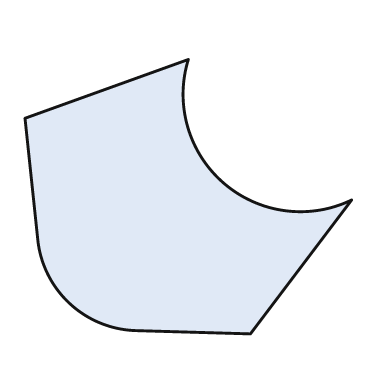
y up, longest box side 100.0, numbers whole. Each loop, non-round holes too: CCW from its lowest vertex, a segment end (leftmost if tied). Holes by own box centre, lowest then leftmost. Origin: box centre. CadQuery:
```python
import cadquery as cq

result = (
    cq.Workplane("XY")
    .moveTo(19.0, -42.0)
    .lineTo(50.0, -1.0)
    .threePointArc((11.0, 4.0), (0.0, 42.0))
    .lineTo(-50.0, 24.0)
    .lineTo(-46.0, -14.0)
    .threePointArc((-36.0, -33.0), (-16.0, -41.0))
    .close()
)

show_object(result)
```